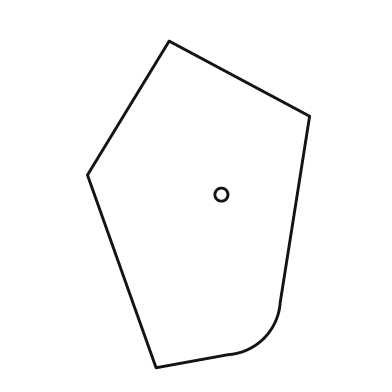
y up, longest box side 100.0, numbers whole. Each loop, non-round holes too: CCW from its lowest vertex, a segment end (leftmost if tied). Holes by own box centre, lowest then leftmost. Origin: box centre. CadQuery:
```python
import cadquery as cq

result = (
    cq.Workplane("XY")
    .moveTo(-13.0, -50.0)
    .lineTo(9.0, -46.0)
    .threePointArc((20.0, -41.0), (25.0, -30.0))
    .lineTo(34.0, 27.0)
    .lineTo(-9.0, 50.0)
    .lineTo(-34.0, 9.0)
    .close()
    .moveTo(7.0, 3.0)
    .circle(2.0)
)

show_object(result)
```